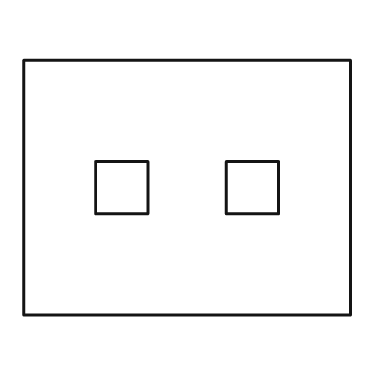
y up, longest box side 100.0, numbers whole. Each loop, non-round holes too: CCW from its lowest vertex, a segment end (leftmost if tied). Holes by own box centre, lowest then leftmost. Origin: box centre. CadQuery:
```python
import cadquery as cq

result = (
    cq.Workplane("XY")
    .moveTo(-50.0, -39.0)
    .lineTo(50.0, -39.0)
    .lineTo(50.0, 39.0)
    .lineTo(-50.0, 39.0)
    .close()
    .moveTo(-28.0, -8.0)
    .lineTo(-12.0, -8.0)
    .lineTo(-12.0, 8.0)
    .lineTo(-28.0, 8.0)
    .close()
    .moveTo(12.0, -8.0)
    .lineTo(28.0, -8.0)
    .lineTo(28.0, 8.0)
    .lineTo(12.0, 8.0)
    .close()
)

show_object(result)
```